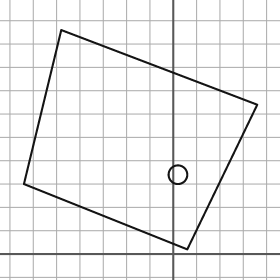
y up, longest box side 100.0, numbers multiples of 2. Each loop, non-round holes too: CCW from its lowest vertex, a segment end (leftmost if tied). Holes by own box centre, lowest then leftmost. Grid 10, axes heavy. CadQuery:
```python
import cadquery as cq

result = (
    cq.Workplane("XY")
    .moveTo(6.0, 2.0)
    .lineTo(36.0, 64.0)
    .lineTo(-48.0, 96.0)
    .lineTo(-64.0, 30.0)
    .close()
    .moveTo(2.0, 34.0)
    .circle(4.0)
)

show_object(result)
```